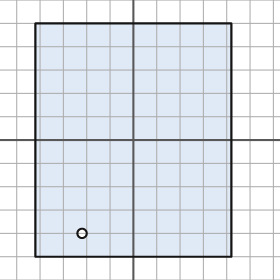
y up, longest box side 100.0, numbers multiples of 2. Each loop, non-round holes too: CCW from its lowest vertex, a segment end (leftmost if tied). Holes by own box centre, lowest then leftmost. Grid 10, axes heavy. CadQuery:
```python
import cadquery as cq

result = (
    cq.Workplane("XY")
    .moveTo(-42.0, -50.0)
    .lineTo(42.0, -50.0)
    .lineTo(42.0, 50.0)
    .lineTo(-42.0, 50.0)
    .close()
    .moveTo(-22.0, -40.0)
    .circle(2.0)
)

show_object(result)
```